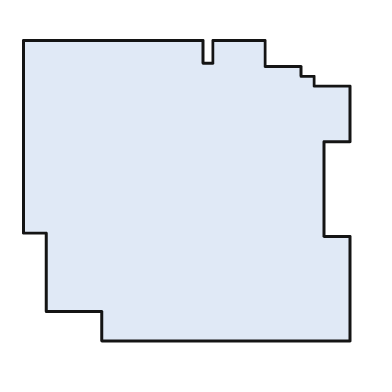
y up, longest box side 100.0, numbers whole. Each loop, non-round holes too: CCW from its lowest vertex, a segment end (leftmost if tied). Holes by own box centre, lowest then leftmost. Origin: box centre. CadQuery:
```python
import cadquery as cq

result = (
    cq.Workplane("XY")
    .moveTo(-26.0, -46.0)
    .lineTo(50.0, -46.0)
    .lineTo(50.0, -14.0)
    .lineTo(42.0, -14.0)
    .lineTo(42.0, 15.0)
    .lineTo(50.0, 15.0)
    .lineTo(50.0, 32.0)
    .lineTo(39.0, 32.0)
    .lineTo(39.0, 35.0)
    .lineTo(35.0, 35.0)
    .lineTo(35.0, 38.0)
    .lineTo(24.0, 38.0)
    .lineTo(24.0, 46.0)
    .lineTo(8.0, 46.0)
    .lineTo(8.0, 39.0)
    .lineTo(5.0, 39.0)
    .lineTo(5.0, 46.0)
    .lineTo(-50.0, 46.0)
    .lineTo(-50.0, -13.0)
    .lineTo(-43.0, -13.0)
    .lineTo(-43.0, -37.0)
    .lineTo(-26.0, -37.0)
    .close()
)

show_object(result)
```